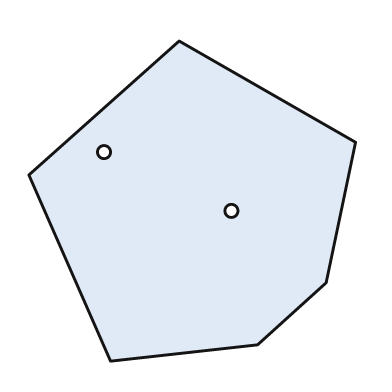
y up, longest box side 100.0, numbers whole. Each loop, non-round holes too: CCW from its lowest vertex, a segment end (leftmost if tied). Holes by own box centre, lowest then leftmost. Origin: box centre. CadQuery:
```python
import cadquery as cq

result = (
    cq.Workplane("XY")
    .moveTo(-25.0, -49.0)
    .lineTo(20.0, -44.0)
    .lineTo(41.0, -25.0)
    .lineTo(50.0, 18.0)
    .lineTo(-4.0, 49.0)
    .lineTo(-50.0, 8.0)
    .close()
    .moveTo(12.0, -3.0)
    .circle(2.0)
    .moveTo(-27.0, 15.0)
    .circle(2.0)
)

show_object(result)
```